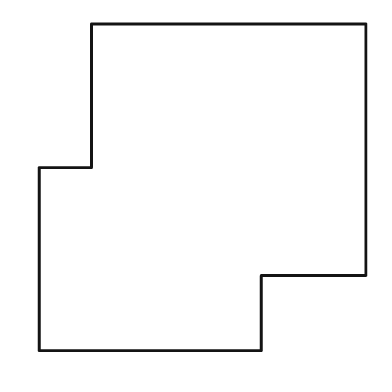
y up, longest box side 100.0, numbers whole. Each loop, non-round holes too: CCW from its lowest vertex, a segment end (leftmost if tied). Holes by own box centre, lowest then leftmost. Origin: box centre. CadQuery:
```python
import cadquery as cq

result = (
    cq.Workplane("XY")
    .moveTo(-50.0, -50.0)
    .lineTo(18.0, -50.0)
    .lineTo(18.0, -27.0)
    .lineTo(50.0, -27.0)
    .lineTo(50.0, 50.0)
    .lineTo(-34.0, 50.0)
    .lineTo(-34.0, 6.0)
    .lineTo(-50.0, 6.0)
    .close()
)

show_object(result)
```